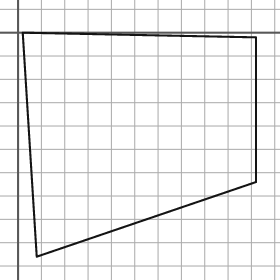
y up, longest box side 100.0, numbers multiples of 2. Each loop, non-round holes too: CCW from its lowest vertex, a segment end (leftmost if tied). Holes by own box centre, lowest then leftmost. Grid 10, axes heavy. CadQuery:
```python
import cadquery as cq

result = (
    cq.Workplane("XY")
    .moveTo(8.0, -96.0)
    .lineTo(102.0, -64.0)
    .lineTo(102.0, -2.0)
    .lineTo(2.0, 0.0)
    .close()
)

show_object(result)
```